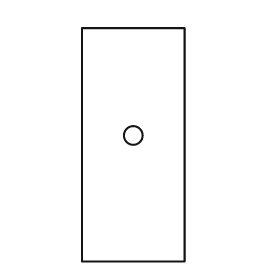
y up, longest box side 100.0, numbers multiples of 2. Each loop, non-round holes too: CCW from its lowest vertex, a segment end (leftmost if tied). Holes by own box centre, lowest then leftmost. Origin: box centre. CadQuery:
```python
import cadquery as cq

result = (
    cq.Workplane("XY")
    .moveTo(-22.0, -50.0)
    .lineTo(22.0, -50.0)
    .lineTo(22.0, 50.0)
    .lineTo(-22.0, 50.0)
    .close()
    .moveTo(0.0, 4.0)
    .circle(4.0)
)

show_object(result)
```